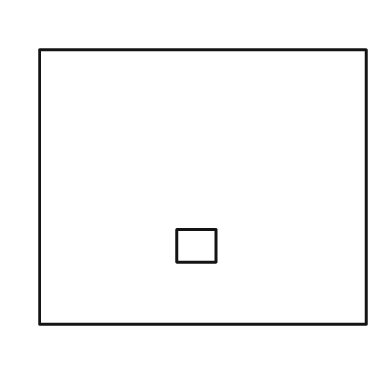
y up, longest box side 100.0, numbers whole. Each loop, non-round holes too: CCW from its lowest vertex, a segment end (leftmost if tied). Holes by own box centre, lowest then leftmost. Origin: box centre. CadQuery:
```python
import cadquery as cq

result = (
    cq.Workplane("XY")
    .moveTo(-50.0, -42.0)
    .lineTo(50.0, -42.0)
    .lineTo(50.0, 42.0)
    .lineTo(-50.0, 42.0)
    .close()
    .moveTo(-8.0, -23.0)
    .lineTo(4.0, -23.0)
    .lineTo(4.0, -13.0)
    .lineTo(-8.0, -13.0)
    .close()
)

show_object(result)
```